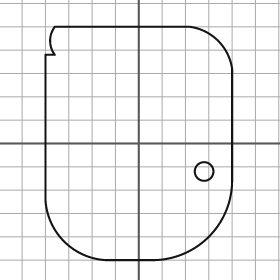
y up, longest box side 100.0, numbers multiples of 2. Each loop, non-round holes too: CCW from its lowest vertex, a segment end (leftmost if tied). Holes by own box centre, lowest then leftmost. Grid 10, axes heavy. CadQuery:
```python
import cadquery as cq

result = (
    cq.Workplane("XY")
    .moveTo(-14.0, -50.0)
    .lineTo(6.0, -50.0)
    .threePointArc((30.0, -40.0), (40.0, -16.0))
    .lineTo(40.0, 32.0)
    .threePointArc((34.0, 44.0), (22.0, 50.0))
    .lineTo(-36.0, 50.0)
    .threePointArc((-38.0, 44.0), (-36.0, 38.0))
    .lineTo(-40.0, 38.0)
    .lineTo(-40.0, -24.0)
    .threePointArc((-32.0, -42.0), (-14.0, -50.0))
    .close()
    .moveTo(28.0, -12.0)
    .circle(4.0)
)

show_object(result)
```